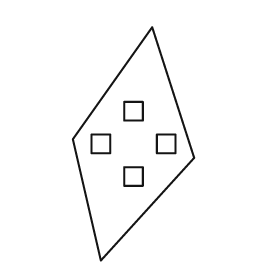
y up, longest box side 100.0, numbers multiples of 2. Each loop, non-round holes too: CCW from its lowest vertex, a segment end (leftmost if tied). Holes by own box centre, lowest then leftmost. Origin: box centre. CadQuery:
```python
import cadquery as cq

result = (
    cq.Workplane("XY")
    .moveTo(-14.0, -50.0)
    .lineTo(26.0, -6.0)
    .lineTo(8.0, 50.0)
    .lineTo(-26.0, 2.0)
    .close()
    .moveTo(-4.0, -18.0)
    .lineTo(4.0, -18.0)
    .lineTo(4.0, -10.0)
    .lineTo(-4.0, -10.0)
    .close()
    .moveTo(-18.0, -4.0)
    .lineTo(-10.0, -4.0)
    .lineTo(-10.0, 4.0)
    .lineTo(-18.0, 4.0)
    .close()
    .moveTo(10.0, -4.0)
    .lineTo(18.0, -4.0)
    .lineTo(18.0, 4.0)
    .lineTo(10.0, 4.0)
    .close()
    .moveTo(-4.0, 10.0)
    .lineTo(4.0, 10.0)
    .lineTo(4.0, 18.0)
    .lineTo(-4.0, 18.0)
    .close()
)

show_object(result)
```